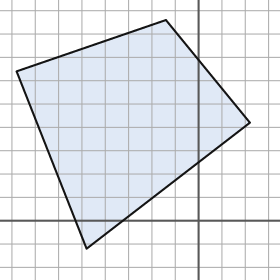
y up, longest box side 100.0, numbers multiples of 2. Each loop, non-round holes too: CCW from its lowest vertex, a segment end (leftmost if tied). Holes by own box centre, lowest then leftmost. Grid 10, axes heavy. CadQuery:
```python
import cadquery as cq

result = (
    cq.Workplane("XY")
    .moveTo(-48.0, -12.0)
    .lineTo(22.0, 42.0)
    .lineTo(-14.0, 86.0)
    .lineTo(-78.0, 64.0)
    .close()
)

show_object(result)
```